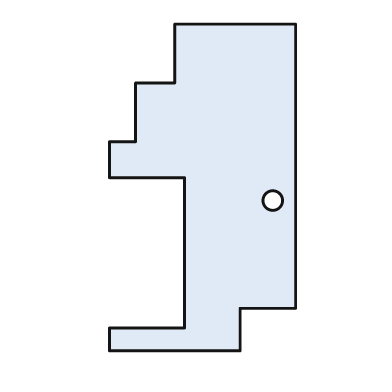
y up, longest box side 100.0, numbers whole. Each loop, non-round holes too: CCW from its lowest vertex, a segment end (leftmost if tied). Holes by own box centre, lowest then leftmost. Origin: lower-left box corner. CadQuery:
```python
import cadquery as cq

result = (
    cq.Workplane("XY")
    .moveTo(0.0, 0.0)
    .lineTo(40.0, 0.0)
    .lineTo(40.0, 13.0)
    .lineTo(57.0, 13.0)
    .lineTo(57.0, 100.0)
    .lineTo(20.0, 100.0)
    .lineTo(20.0, 82.0)
    .lineTo(8.0, 82.0)
    .lineTo(8.0, 64.0)
    .lineTo(0.0, 64.0)
    .lineTo(0.0, 53.0)
    .lineTo(23.0, 53.0)
    .lineTo(23.0, 7.0)
    .lineTo(0.0, 7.0)
    .close()
    .moveTo(50.0, 46.0)
    .circle(3.0)
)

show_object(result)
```